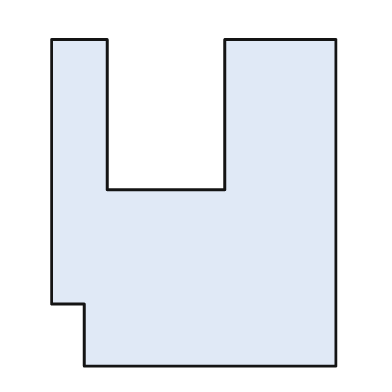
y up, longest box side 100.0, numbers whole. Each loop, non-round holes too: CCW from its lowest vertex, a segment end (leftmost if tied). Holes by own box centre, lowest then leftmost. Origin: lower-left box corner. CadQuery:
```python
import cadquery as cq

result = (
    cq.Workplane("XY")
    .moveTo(10.0, 0.0)
    .lineTo(87.0, 0.0)
    .lineTo(87.0, 100.0)
    .lineTo(53.0, 100.0)
    .lineTo(53.0, 54.0)
    .lineTo(17.0, 54.0)
    .lineTo(17.0, 100.0)
    .lineTo(0.0, 100.0)
    .lineTo(0.0, 19.0)
    .lineTo(10.0, 19.0)
    .close()
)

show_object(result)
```